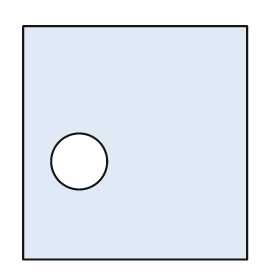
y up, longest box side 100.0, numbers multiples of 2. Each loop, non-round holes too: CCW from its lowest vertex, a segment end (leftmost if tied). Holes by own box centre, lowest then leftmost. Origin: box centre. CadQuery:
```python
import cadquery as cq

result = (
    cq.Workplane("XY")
    .moveTo(-48.0, -50.0)
    .lineTo(48.0, -50.0)
    .lineTo(48.0, 50.0)
    .lineTo(-48.0, 50.0)
    .close()
    .moveTo(-24.0, -8.0)
    .circle(12.0)
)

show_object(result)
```